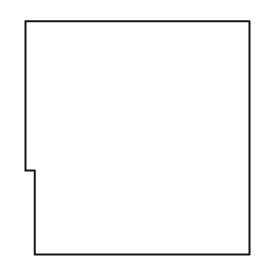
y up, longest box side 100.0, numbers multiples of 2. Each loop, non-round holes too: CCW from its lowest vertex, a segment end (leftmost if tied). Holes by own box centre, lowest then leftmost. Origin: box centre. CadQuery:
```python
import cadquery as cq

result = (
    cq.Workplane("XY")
    .moveTo(-44.0, -50.0)
    .lineTo(48.0, -50.0)
    .lineTo(48.0, 50.0)
    .lineTo(-48.0, 50.0)
    .lineTo(-48.0, -14.0)
    .lineTo(-44.0, -14.0)
    .close()
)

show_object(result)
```